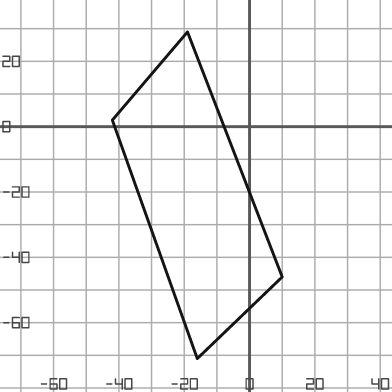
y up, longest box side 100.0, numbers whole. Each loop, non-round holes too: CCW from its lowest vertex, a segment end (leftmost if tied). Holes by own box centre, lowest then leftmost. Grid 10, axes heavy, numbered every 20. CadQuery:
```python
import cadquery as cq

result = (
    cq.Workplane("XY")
    .moveTo(-16.0, -71.0)
    .lineTo(10.0, -46.0)
    .lineTo(-19.0, 29.0)
    .lineTo(-42.0, 2.0)
    .close()
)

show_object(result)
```